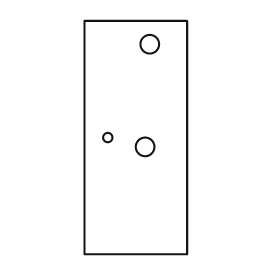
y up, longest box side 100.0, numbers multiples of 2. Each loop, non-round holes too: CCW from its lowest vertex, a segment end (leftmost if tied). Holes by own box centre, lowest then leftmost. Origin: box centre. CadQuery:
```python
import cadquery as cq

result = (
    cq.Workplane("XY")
    .moveTo(-22.0, -50.0)
    .lineTo(22.0, -50.0)
    .lineTo(22.0, 50.0)
    .lineTo(-22.0, 50.0)
    .close()
    .moveTo(4.0, -4.0)
    .circle(4.0)
    .moveTo(-12.0, 0.0)
    .circle(2.0)
    .moveTo(6.0, 40.0)
    .circle(4.0)
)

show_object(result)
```